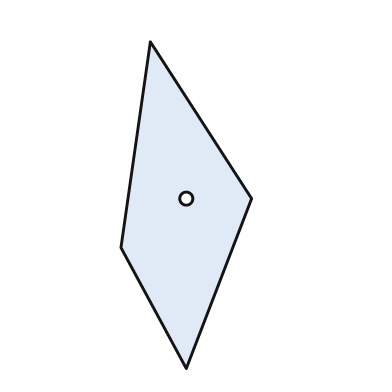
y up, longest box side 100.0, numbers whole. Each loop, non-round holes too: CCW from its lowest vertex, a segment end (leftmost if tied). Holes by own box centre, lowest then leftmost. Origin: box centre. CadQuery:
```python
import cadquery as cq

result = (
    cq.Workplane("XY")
    .moveTo(0.0, -50.0)
    .lineTo(20.0, 2.0)
    .lineTo(-11.0, 50.0)
    .lineTo(-20.0, -13.0)
    .close()
    .moveTo(0.0, 2.0)
    .circle(2.0)
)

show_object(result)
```